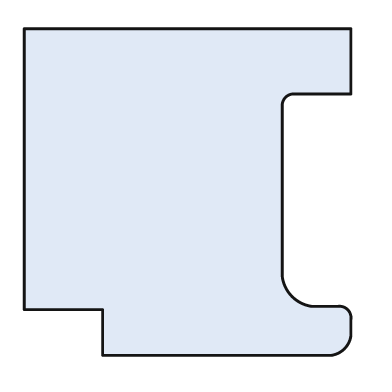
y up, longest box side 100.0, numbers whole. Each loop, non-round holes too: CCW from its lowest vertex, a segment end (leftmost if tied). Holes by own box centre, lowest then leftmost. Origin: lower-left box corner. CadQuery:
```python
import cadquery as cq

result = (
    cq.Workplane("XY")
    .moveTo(24.0, 0.0)
    .lineTo(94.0, 0.0)
    .threePointArc((98.0, 2.0), (100.0, 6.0))
    .lineTo(100.0, 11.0)
    .threePointArc((99.0, 14.0), (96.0, 15.0))
    .lineTo(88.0, 15.0)
    .threePointArc((82.0, 18.0), (79.0, 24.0))
    .lineTo(79.0, 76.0)
    .threePointArc((80.0, 79.0), (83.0, 80.0))
    .lineTo(100.0, 80.0)
    .lineTo(100.0, 100.0)
    .lineTo(0.0, 100.0)
    .lineTo(0.0, 14.0)
    .lineTo(24.0, 14.0)
    .close()
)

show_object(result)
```